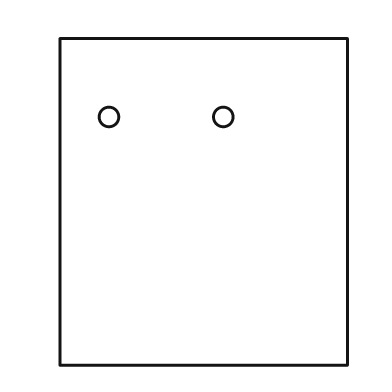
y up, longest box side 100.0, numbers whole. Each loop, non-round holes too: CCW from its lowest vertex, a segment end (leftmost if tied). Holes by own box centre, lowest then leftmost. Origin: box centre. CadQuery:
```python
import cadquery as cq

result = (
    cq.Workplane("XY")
    .moveTo(-44.0, -50.0)
    .lineTo(44.0, -50.0)
    .lineTo(44.0, 50.0)
    .lineTo(-44.0, 50.0)
    .close()
    .moveTo(-29.0, 26.0)
    .circle(3.0)
    .moveTo(6.0, 26.0)
    .circle(3.0)
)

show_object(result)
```